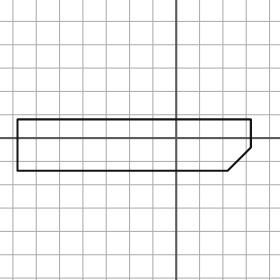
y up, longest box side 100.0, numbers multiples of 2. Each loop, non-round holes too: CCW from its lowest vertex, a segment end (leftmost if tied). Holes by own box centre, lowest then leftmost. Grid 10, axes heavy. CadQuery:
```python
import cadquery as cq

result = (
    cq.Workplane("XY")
    .moveTo(-68.0, -14.0)
    .lineTo(22.0, -14.0)
    .lineTo(32.0, -4.0)
    .lineTo(32.0, 8.0)
    .lineTo(-68.0, 8.0)
    .close()
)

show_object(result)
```